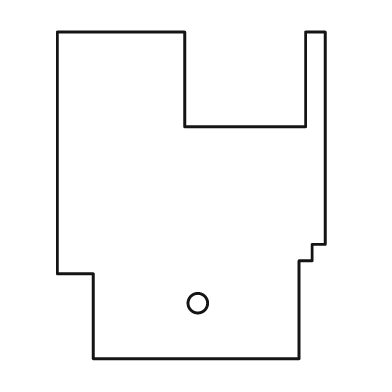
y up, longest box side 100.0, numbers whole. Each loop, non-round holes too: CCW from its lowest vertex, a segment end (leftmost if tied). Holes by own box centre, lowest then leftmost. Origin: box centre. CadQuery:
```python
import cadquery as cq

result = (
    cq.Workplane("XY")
    .moveTo(-30.0, -50.0)
    .lineTo(33.0, -50.0)
    .lineTo(33.0, -20.0)
    .lineTo(37.0, -20.0)
    .lineTo(37.0, -15.0)
    .lineTo(41.0, -15.0)
    .lineTo(41.0, 50.0)
    .lineTo(35.0, 50.0)
    .lineTo(35.0, 21.0)
    .lineTo(-2.0, 21.0)
    .lineTo(-2.0, 50.0)
    .lineTo(-41.0, 50.0)
    .lineTo(-41.0, -24.0)
    .lineTo(-30.0, -24.0)
    .close()
    .moveTo(2.0, -33.0)
    .circle(3.0)
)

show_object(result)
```